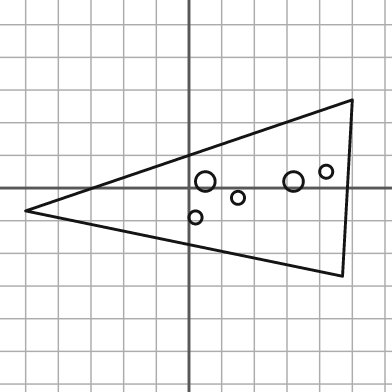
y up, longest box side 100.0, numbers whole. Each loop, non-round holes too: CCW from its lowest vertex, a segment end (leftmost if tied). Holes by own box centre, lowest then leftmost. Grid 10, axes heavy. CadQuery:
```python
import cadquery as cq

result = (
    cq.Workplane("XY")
    .moveTo(47.0, -27.0)
    .lineTo(50.0, 27.0)
    .lineTo(-50.0, -7.0)
    .close()
    .moveTo(2.0, -9.0)
    .circle(2.0)
    .moveTo(15.0, -3.0)
    .circle(2.0)
    .moveTo(5.0, 2.0)
    .circle(3.0)
    .moveTo(32.0, 2.0)
    .circle(3.0)
    .moveTo(42.0, 5.0)
    .circle(2.0)
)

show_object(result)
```